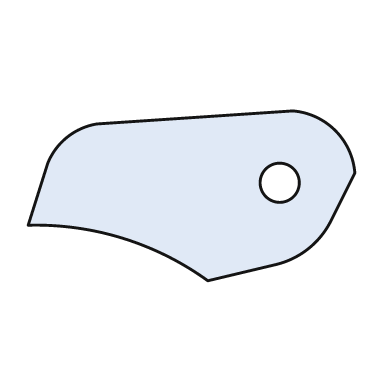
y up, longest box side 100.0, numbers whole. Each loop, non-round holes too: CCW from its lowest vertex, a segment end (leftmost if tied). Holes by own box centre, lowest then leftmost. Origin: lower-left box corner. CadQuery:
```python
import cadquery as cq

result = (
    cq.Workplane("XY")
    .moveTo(55.0, 0.0)
    .lineTo(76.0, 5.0)
    .threePointArc((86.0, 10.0), (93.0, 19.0))
    .lineTo(100.0, 33.0)
    .threePointArc((94.0, 46.0), (81.0, 52.0))
    .lineTo(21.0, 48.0)
    .threePointArc((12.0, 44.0), (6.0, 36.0))
    .lineTo(0.0, 17.0)
    .threePointArc((29.0, 13.0), (55.0, 0.0))
    .close()
    .moveTo(77.0, 30.0)
    .circle(6.0)
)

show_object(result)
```